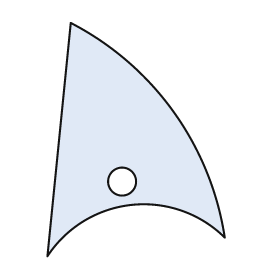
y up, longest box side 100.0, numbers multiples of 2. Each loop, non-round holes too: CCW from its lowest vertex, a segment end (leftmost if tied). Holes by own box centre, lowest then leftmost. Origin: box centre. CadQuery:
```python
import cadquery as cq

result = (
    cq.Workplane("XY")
    .moveTo(-38.0, -50.0)
    .threePointArc((-2.0, -28.0), (38.0, -42.0))
    .threePointArc((16.0, 12.0), (-28.0, 50.0))
    .close()
    .moveTo(-6.0, -18.0)
    .circle(6.0)
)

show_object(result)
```